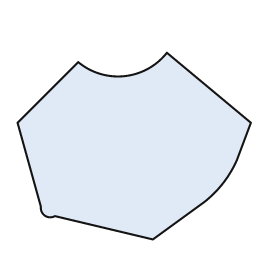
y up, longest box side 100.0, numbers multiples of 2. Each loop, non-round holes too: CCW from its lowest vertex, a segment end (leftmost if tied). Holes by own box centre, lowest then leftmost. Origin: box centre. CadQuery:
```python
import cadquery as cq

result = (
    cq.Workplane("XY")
    .moveTo(8.0, -40.0)
    .lineTo(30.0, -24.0)
    .threePointArc((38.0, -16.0), (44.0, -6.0))
    .lineTo(50.0, 10.0)
    .lineTo(14.0, 40.0)
    .threePointArc((-4.0, 30.0), (-24.0, 36.0))
    .lineTo(-50.0, 10.0)
    .lineTo(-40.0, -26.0)
    .threePointArc((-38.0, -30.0), (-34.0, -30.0))
    .close()
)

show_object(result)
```